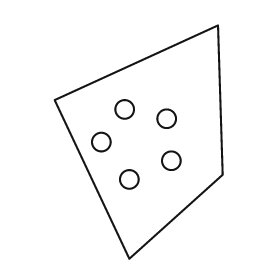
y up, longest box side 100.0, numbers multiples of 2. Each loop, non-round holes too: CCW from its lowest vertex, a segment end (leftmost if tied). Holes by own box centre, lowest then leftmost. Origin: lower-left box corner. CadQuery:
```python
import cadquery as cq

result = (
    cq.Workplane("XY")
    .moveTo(32.0, 0.0)
    .lineTo(72.0, 36.0)
    .lineTo(70.0, 100.0)
    .lineTo(0.0, 68.0)
    .close()
    .moveTo(32.0, 34.0)
    .circle(4.0)
    .moveTo(50.0, 42.0)
    .circle(4.0)
    .moveTo(20.0, 50.0)
    .circle(4.0)
    .moveTo(48.0, 60.0)
    .circle(4.0)
    .moveTo(30.0, 64.0)
    .circle(4.0)
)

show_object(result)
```